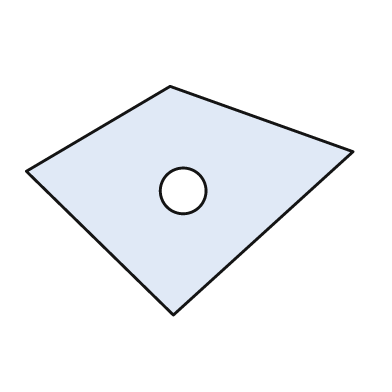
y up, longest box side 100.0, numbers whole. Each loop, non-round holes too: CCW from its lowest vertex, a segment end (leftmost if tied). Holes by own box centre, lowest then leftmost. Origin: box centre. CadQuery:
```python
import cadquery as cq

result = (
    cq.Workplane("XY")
    .moveTo(-5.0, -35.0)
    .lineTo(50.0, 15.0)
    .lineTo(-6.0, 35.0)
    .lineTo(-50.0, 9.0)
    .close()
    .moveTo(-2.0, 3.0)
    .circle(7.0)
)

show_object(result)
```